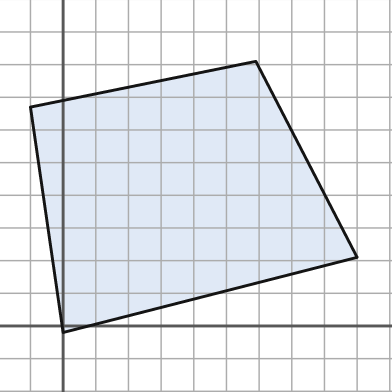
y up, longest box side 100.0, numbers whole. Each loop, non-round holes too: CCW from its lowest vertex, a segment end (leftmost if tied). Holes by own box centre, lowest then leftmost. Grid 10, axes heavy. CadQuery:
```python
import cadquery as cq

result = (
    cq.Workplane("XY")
    .moveTo(0.0, -2.0)
    .lineTo(90.0, 21.0)
    .lineTo(59.0, 81.0)
    .lineTo(-10.0, 67.0)
    .close()
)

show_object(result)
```